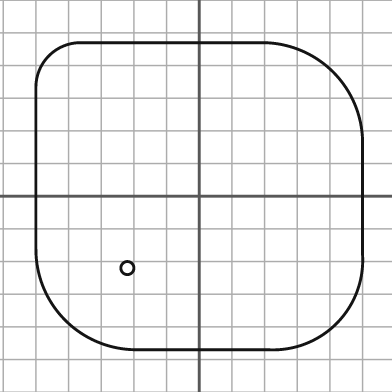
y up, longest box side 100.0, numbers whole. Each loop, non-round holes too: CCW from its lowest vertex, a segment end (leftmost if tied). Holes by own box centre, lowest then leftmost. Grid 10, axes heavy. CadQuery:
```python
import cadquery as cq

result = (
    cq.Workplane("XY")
    .moveTo(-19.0, -47.0)
    .lineTo(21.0, -47.0)
    .threePointArc((42.0, -39.0), (50.0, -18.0))
    .lineTo(50.0, 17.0)
    .threePointArc((41.0, 38.0), (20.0, 47.0))
    .lineTo(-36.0, 47.0)
    .threePointArc((-46.0, 43.0), (-50.0, 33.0))
    .lineTo(-50.0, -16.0)
    .threePointArc((-41.0, -38.0), (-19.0, -47.0))
    .close()
    .moveTo(-22.0, -22.0)
    .circle(2.0)
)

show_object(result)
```